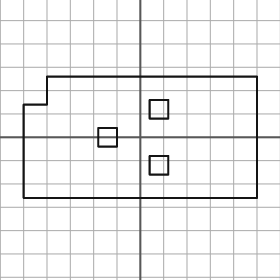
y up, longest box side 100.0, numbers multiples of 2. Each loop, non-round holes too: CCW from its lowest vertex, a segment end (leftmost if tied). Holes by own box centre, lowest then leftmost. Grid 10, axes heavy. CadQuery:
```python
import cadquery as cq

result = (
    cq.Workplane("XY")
    .moveTo(-50.0, -26.0)
    .lineTo(50.0, -26.0)
    .lineTo(50.0, 26.0)
    .lineTo(-40.0, 26.0)
    .lineTo(-40.0, 14.0)
    .lineTo(-50.0, 14.0)
    .close()
    .moveTo(4.0, -16.0)
    .lineTo(12.0, -16.0)
    .lineTo(12.0, -8.0)
    .lineTo(4.0, -8.0)
    .close()
    .moveTo(-18.0, -4.0)
    .lineTo(-10.0, -4.0)
    .lineTo(-10.0, 4.0)
    .lineTo(-18.0, 4.0)
    .close()
    .moveTo(4.0, 8.0)
    .lineTo(12.0, 8.0)
    .lineTo(12.0, 16.0)
    .lineTo(4.0, 16.0)
    .close()
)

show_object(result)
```